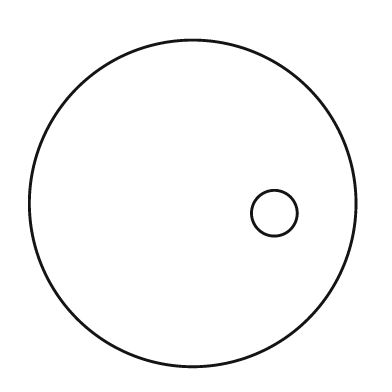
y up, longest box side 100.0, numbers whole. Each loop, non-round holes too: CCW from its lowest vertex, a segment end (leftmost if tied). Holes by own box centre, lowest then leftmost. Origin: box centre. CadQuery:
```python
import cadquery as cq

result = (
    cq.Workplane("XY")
    .moveTo(0.0, 0.0)
    .circle(50.0)
    .moveTo(25.0, -3.0)
    .circle(7.0)
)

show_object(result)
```